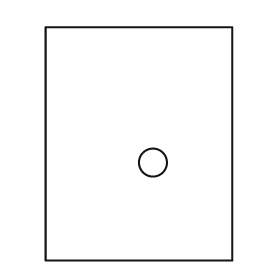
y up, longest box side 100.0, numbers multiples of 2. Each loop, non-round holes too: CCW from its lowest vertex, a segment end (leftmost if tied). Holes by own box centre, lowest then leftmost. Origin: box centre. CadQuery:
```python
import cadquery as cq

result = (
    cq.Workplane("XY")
    .moveTo(-40.0, -50.0)
    .lineTo(40.0, -50.0)
    .lineTo(40.0, 50.0)
    .lineTo(-40.0, 50.0)
    .close()
    .moveTo(6.0, -8.0)
    .circle(6.0)
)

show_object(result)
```